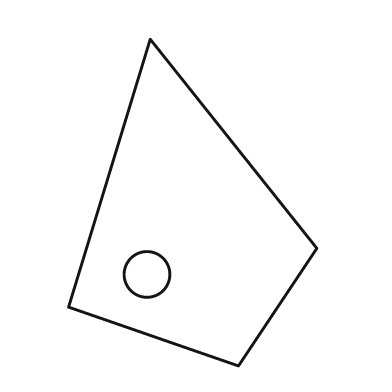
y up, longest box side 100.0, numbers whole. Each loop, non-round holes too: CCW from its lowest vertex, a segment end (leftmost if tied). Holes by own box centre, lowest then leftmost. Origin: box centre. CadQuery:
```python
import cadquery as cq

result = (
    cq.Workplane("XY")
    .moveTo(14.0, -50.0)
    .lineTo(38.0, -14.0)
    .lineTo(-13.0, 50.0)
    .lineTo(-38.0, -32.0)
    .close()
    .moveTo(-14.0, -22.0)
    .circle(7.0)
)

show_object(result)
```